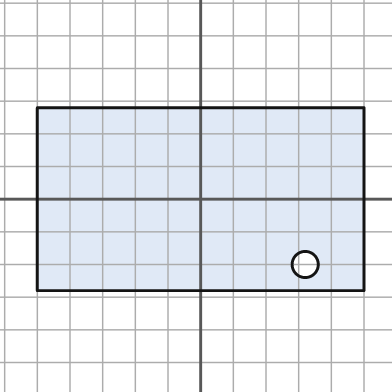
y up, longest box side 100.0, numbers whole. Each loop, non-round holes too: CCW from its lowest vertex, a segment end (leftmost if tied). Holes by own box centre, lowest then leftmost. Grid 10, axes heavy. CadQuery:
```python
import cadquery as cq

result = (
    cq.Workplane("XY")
    .moveTo(-50.0, -28.0)
    .lineTo(50.0, -28.0)
    .lineTo(50.0, 28.0)
    .lineTo(-50.0, 28.0)
    .close()
    .moveTo(32.0, -20.0)
    .circle(4.0)
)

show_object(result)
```